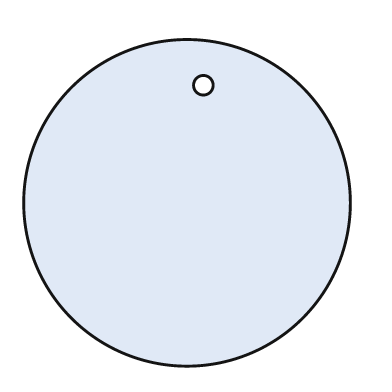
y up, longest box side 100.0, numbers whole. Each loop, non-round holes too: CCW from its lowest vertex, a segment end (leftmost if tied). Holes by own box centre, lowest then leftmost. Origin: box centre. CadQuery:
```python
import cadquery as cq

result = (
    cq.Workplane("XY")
    .moveTo(0.0, 0.0)
    .circle(50.0)
    .moveTo(5.0, 36.0)
    .circle(3.0)
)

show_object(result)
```